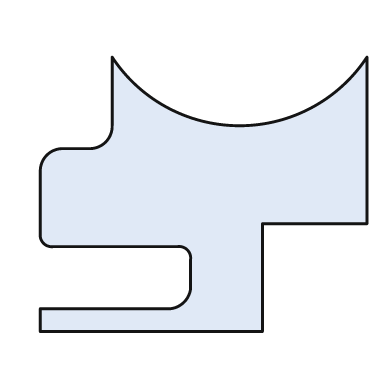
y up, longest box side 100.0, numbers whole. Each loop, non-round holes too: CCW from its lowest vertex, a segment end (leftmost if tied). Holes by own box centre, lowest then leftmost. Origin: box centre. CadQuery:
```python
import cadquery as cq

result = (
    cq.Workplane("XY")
    .moveTo(-50.0, -42.0)
    .lineTo(18.0, -42.0)
    .lineTo(18.0, -9.0)
    .lineTo(50.0, -9.0)
    .lineTo(50.0, 42.0)
    .threePointArc((11.0, 21.0), (-28.0, 42.0))
    .lineTo(-28.0, 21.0)
    .threePointArc((-30.0, 16.0), (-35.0, 14.0))
    .lineTo(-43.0, 14.0)
    .threePointArc((-48.0, 12.0), (-50.0, 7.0))
    .lineTo(-50.0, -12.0)
    .threePointArc((-49.0, -15.0), (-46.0, -16.0))
    .lineTo(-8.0, -16.0)
    .threePointArc((-5.0, -17.0), (-4.0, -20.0))
    .lineTo(-4.0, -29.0)
    .threePointArc((-6.0, -33.0), (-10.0, -35.0))
    .lineTo(-50.0, -35.0)
    .close()
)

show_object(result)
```